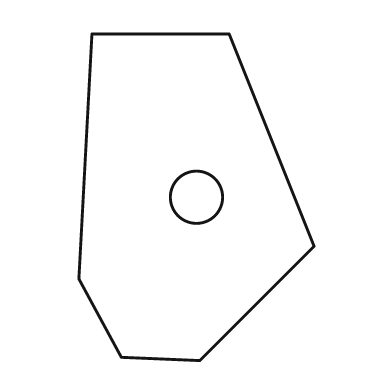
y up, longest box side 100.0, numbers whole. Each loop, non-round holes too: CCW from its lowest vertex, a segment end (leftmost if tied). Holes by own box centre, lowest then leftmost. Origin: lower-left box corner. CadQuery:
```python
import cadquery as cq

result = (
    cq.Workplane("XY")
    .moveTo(37.0, 0.0)
    .lineTo(72.0, 35.0)
    .lineTo(46.0, 100.0)
    .lineTo(4.0, 100.0)
    .lineTo(0.0, 25.0)
    .lineTo(13.0, 1.0)
    .close()
    .moveTo(36.0, 50.0)
    .circle(8.0)
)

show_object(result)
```